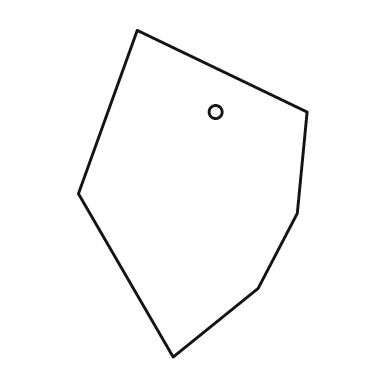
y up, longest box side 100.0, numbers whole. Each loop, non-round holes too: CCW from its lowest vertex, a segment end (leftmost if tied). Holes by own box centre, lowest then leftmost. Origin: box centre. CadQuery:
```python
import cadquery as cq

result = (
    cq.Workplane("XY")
    .moveTo(-6.0, -50.0)
    .lineTo(20.0, -29.0)
    .lineTo(32.0, -6.0)
    .lineTo(35.0, 25.0)
    .lineTo(-17.0, 50.0)
    .lineTo(-35.0, 0.0)
    .close()
    .moveTo(7.0, 25.0)
    .circle(2.0)
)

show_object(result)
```